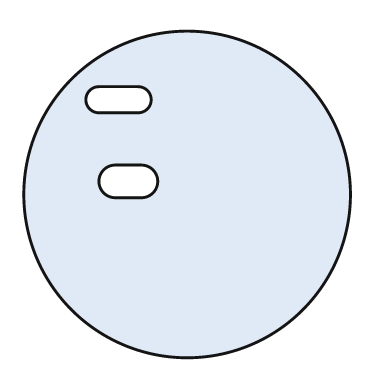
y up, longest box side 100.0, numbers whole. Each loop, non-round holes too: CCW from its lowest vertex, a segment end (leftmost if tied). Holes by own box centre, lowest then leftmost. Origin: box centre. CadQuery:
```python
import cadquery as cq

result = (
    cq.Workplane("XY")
    .moveTo(0.0, 0.0)
    .circle(50.0)
    .moveTo(-22.0, -1.0)
    .lineTo(-14.0, -1.0)
    .threePointArc((-9.0, 4.0), (-14.0, 9.0))
    .lineTo(-22.0, 9.0)
    .threePointArc((-27.0, 4.0), (-22.0, -1.0))
    .close()
    .moveTo(-27.0, 25.0)
    .lineTo(-15.0, 25.0)
    .threePointArc((-11.0, 29.0), (-15.0, 33.0))
    .lineTo(-27.0, 33.0)
    .threePointArc((-31.0, 29.0), (-27.0, 25.0))
    .close()
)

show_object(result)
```